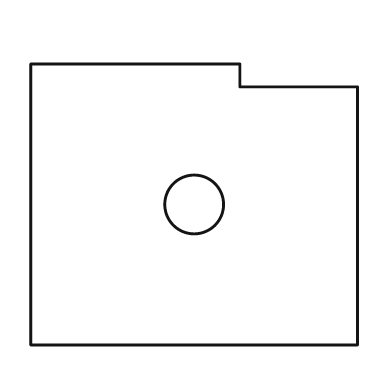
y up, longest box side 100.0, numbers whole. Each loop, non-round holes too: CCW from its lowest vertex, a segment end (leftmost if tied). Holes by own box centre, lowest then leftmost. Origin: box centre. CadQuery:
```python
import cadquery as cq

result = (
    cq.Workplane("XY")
    .moveTo(-50.0, -43.0)
    .lineTo(50.0, -43.0)
    .lineTo(50.0, 36.0)
    .lineTo(14.0, 36.0)
    .lineTo(14.0, 43.0)
    .lineTo(-50.0, 43.0)
    .close()
    .moveTo(0.0, 0.0)
    .circle(9.0)
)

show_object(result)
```